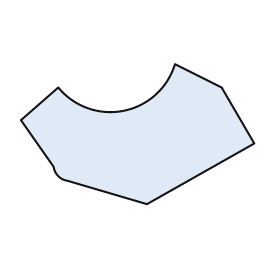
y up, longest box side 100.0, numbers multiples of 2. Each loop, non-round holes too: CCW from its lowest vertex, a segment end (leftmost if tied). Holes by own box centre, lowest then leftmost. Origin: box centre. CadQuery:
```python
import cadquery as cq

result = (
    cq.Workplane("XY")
    .moveTo(4.0, -30.0)
    .lineTo(50.0, -4.0)
    .lineTo(36.0, 20.0)
    .lineTo(16.0, 30.0)
    .threePointArc((-6.0, 10.0), (-34.0, 20.0))
    .lineTo(-50.0, 6.0)
    .lineTo(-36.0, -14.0)
    .threePointArc((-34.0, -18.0), (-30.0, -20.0))
    .close()
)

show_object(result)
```